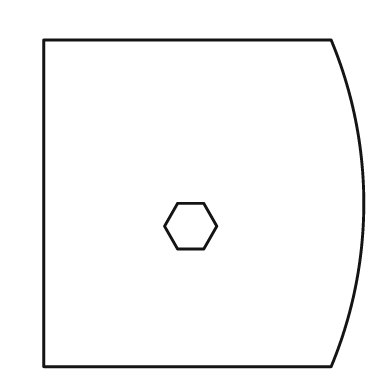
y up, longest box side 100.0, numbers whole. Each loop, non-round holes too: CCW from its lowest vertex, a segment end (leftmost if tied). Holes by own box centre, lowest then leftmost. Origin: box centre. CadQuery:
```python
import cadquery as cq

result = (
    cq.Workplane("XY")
    .moveTo(-49.0, -50.0)
    .lineTo(39.0, -50.0)
    .threePointArc((49.0, 0.0), (39.0, 50.0))
    .lineTo(-49.0, 50.0)
    .close()
    .moveTo(-8.0, -14.0)
    .lineTo(0.0, -14.0)
    .lineTo(4.0, -7.0)
    .lineTo(0.0, 0.0)
    .lineTo(-8.0, 0.0)
    .lineTo(-12.0, -7.0)
    .close()
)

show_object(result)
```